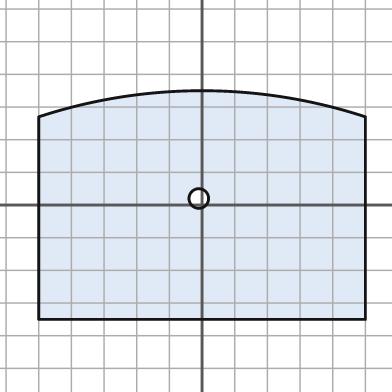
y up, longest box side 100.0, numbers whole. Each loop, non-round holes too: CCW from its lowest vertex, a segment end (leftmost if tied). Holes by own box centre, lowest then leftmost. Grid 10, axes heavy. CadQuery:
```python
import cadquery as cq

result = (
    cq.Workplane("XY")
    .moveTo(-50.0, -35.0)
    .lineTo(50.0, -35.0)
    .lineTo(50.0, 27.0)
    .threePointArc((0.0, 35.0), (-50.0, 27.0))
    .close()
    .moveTo(-1.0, 2.0)
    .circle(3.0)
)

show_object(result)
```